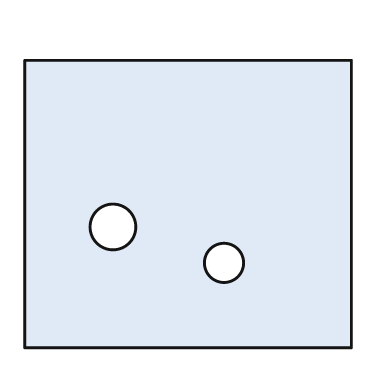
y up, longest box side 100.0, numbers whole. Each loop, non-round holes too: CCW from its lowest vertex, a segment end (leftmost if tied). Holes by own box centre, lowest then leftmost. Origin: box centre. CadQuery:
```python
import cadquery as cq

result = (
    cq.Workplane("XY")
    .moveTo(-50.0, -44.0)
    .lineTo(50.0, -44.0)
    .lineTo(50.0, 44.0)
    .lineTo(-50.0, 44.0)
    .close()
    .moveTo(11.0, -18.0)
    .circle(6.0)
    .moveTo(-23.0, -7.0)
    .circle(7.0)
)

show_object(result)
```